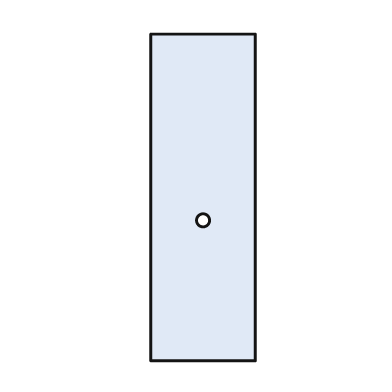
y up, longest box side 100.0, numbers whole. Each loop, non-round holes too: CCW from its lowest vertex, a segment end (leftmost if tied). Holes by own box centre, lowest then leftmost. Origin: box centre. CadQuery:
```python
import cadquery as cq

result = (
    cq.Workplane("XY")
    .moveTo(-16.0, -50.0)
    .lineTo(16.0, -50.0)
    .lineTo(16.0, 50.0)
    .lineTo(-16.0, 50.0)
    .close()
    .moveTo(0.0, -7.0)
    .circle(2.0)
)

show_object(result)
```